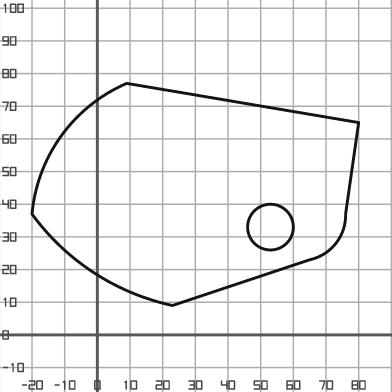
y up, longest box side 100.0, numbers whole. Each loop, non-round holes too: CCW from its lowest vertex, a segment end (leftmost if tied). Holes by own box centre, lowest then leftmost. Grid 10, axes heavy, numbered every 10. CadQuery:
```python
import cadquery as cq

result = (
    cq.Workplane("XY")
    .moveTo(23.0, 9.0)
    .lineTo(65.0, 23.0)
    .threePointArc((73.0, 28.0), (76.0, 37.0))
    .lineTo(80.0, 65.0)
    .lineTo(9.0, 77.0)
    .threePointArc((-11.0, 61.0), (-20.0, 37.0))
    .threePointArc((-1.0, 19.0), (23.0, 9.0))
    .close()
    .moveTo(53.0, 33.0)
    .circle(7.0)
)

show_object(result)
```